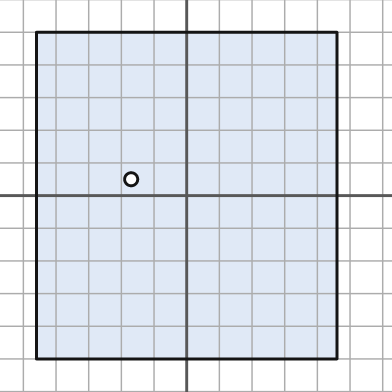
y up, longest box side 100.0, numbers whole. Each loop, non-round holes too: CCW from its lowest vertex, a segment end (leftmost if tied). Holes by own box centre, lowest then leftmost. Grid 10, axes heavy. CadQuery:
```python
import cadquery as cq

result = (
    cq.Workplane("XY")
    .moveTo(-46.0, -50.0)
    .lineTo(46.0, -50.0)
    .lineTo(46.0, 50.0)
    .lineTo(-46.0, 50.0)
    .close()
    .moveTo(-17.0, 5.0)
    .circle(2.0)
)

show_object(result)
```